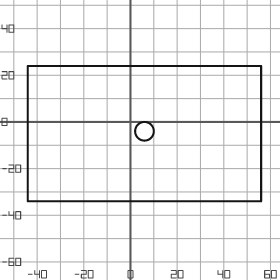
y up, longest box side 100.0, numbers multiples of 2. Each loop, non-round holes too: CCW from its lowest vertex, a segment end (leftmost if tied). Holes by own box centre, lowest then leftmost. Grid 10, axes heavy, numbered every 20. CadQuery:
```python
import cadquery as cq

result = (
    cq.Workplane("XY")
    .moveTo(-44.0, -34.0)
    .lineTo(56.0, -34.0)
    .lineTo(56.0, 24.0)
    .lineTo(-44.0, 24.0)
    .close()
    .moveTo(6.0, -4.0)
    .circle(4.0)
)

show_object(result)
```